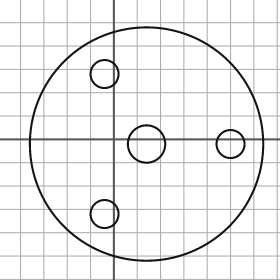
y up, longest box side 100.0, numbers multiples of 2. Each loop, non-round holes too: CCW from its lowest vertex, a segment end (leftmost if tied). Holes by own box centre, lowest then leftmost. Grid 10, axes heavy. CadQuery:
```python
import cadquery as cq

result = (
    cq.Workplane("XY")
    .moveTo(14.0, -2.0)
    .circle(50.0)
    .moveTo(-4.0, -32.0)
    .circle(6.0)
    .moveTo(14.0, -2.0)
    .circle(8.0)
    .moveTo(50.0, -2.0)
    .circle(6.0)
    .moveTo(-4.0, 28.0)
    .circle(6.0)
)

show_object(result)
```